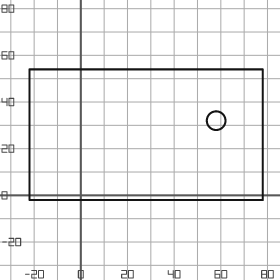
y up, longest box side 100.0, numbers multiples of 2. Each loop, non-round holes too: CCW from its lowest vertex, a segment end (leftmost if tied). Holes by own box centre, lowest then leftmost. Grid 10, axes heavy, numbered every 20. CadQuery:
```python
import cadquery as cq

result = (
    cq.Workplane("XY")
    .moveTo(-22.0, -2.0)
    .lineTo(78.0, -2.0)
    .lineTo(78.0, 54.0)
    .lineTo(-22.0, 54.0)
    .close()
    .moveTo(58.0, 32.0)
    .circle(4.0)
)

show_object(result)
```